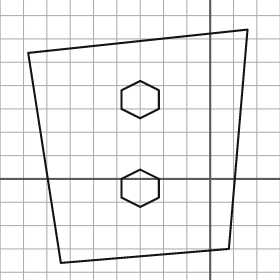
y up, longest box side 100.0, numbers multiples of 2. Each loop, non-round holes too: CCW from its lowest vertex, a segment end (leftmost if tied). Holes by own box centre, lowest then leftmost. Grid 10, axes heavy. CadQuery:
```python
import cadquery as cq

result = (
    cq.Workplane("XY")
    .moveTo(-64.0, -36.0)
    .lineTo(8.0, -30.0)
    .lineTo(16.0, 64.0)
    .lineTo(-78.0, 54.0)
    .close()
    .moveTo(-30.0, -12.0)
    .lineTo(-22.0, -8.0)
    .lineTo(-22.0, 0.0)
    .lineTo(-30.0, 4.0)
    .lineTo(-38.0, 0.0)
    .lineTo(-38.0, -8.0)
    .close()
    .moveTo(-30.0, 26.0)
    .lineTo(-22.0, 30.0)
    .lineTo(-22.0, 38.0)
    .lineTo(-30.0, 42.0)
    .lineTo(-38.0, 38.0)
    .lineTo(-38.0, 30.0)
    .close()
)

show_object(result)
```